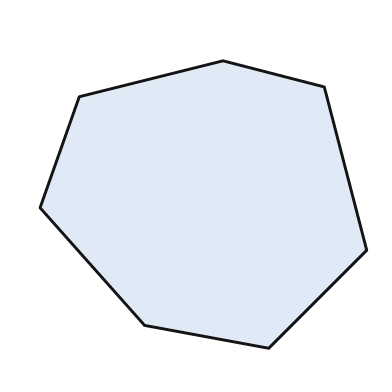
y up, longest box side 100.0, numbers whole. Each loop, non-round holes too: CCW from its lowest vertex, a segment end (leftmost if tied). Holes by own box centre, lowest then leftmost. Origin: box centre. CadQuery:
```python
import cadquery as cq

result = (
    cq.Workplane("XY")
    .moveTo(20.0, -44.0)
    .lineTo(50.0, -14.0)
    .lineTo(37.0, 36.0)
    .lineTo(6.0, 44.0)
    .lineTo(-38.0, 33.0)
    .lineTo(-50.0, -1.0)
    .lineTo(-18.0, -37.0)
    .close()
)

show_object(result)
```